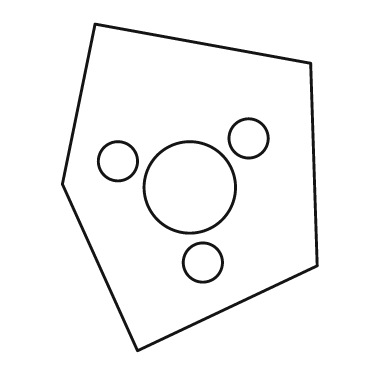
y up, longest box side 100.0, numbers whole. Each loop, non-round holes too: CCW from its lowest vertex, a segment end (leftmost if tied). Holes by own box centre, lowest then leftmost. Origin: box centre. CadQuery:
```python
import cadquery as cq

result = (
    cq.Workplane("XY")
    .moveTo(-16.0, -50.0)
    .lineTo(39.0, -24.0)
    .lineTo(37.0, 38.0)
    .lineTo(-29.0, 50.0)
    .lineTo(-39.0, 1.0)
    .close()
    .moveTo(4.0, -23.0)
    .circle(6.0)
    .moveTo(0.0, 0.0)
    .circle(14.0)
    .moveTo(-22.0, 8.0)
    .circle(6.0)
    .moveTo(18.0, 15.0)
    .circle(6.0)
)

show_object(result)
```